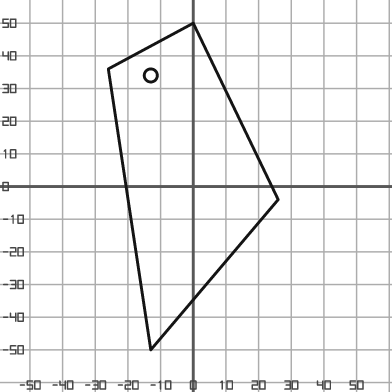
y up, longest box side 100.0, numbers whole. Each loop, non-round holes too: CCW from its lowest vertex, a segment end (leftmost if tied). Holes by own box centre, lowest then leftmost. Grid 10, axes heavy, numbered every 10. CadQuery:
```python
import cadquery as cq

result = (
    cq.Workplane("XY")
    .moveTo(-13.0, -50.0)
    .lineTo(26.0, -4.0)
    .lineTo(0.0, 50.0)
    .lineTo(-26.0, 36.0)
    .close()
    .moveTo(-13.0, 34.0)
    .circle(2.0)
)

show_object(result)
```